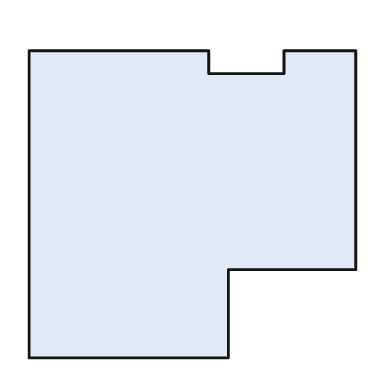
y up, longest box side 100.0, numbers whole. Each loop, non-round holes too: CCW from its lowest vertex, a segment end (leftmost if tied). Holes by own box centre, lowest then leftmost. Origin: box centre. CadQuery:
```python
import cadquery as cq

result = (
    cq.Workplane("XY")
    .moveTo(-50.0, -47.0)
    .lineTo(11.0, -47.0)
    .lineTo(11.0, -20.0)
    .lineTo(50.0, -20.0)
    .lineTo(50.0, 47.0)
    .lineTo(28.0, 47.0)
    .lineTo(28.0, 40.0)
    .lineTo(5.0, 40.0)
    .lineTo(5.0, 47.0)
    .lineTo(-50.0, 47.0)
    .close()
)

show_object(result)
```